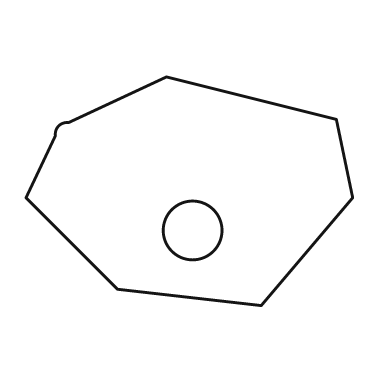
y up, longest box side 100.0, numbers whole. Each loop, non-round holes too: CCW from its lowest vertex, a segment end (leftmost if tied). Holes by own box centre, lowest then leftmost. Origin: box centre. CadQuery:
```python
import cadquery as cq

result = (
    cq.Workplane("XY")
    .moveTo(22.0, -35.0)
    .lineTo(50.0, -2.0)
    .lineTo(45.0, 22.0)
    .lineTo(-7.0, 35.0)
    .lineTo(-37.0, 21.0)
    .threePointArc((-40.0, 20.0), (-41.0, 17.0))
    .lineTo(-50.0, -2.0)
    .lineTo(-22.0, -30.0)
    .close()
    .moveTo(1.0, -12.0)
    .circle(9.0)
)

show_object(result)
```